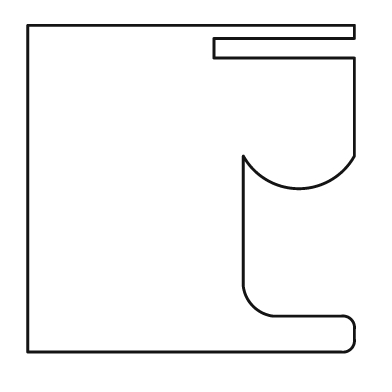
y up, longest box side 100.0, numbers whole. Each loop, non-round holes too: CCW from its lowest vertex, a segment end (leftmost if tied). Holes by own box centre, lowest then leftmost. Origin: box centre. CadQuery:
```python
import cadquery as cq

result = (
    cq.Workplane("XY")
    .moveTo(-50.0, -50.0)
    .lineTo(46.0, -50.0)
    .threePointArc((49.0, -49.0), (50.0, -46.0))
    .lineTo(50.0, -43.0)
    .threePointArc((49.0, -40.0), (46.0, -39.0))
    .lineTo(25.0, -39.0)
    .threePointArc((19.0, -36.0), (16.0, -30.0))
    .lineTo(16.0, 10.0)
    .threePointArc((33.0, 0.0), (50.0, 10.0))
    .lineTo(50.0, 40.0)
    .lineTo(7.0, 40.0)
    .lineTo(7.0, 46.0)
    .lineTo(50.0, 46.0)
    .lineTo(50.0, 50.0)
    .lineTo(-50.0, 50.0)
    .close()
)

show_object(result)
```